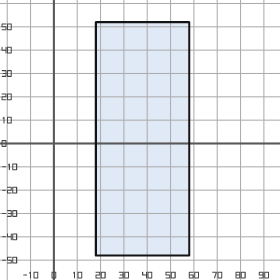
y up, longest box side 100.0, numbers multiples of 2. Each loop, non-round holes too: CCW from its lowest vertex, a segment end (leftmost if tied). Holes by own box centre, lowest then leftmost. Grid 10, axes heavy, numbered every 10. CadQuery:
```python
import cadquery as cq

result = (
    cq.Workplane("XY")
    .moveTo(18.0, -48.0)
    .lineTo(58.0, -48.0)
    .lineTo(58.0, 52.0)
    .lineTo(18.0, 52.0)
    .close()
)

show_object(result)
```